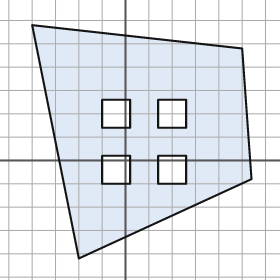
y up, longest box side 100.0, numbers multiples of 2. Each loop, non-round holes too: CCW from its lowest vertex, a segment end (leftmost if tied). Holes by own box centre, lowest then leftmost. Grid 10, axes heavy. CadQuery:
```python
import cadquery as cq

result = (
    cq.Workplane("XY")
    .moveTo(-20.0, -42.0)
    .lineTo(54.0, -8.0)
    .lineTo(50.0, 48.0)
    .lineTo(-40.0, 58.0)
    .close()
    .moveTo(-10.0, -10.0)
    .lineTo(2.0, -10.0)
    .lineTo(2.0, 2.0)
    .lineTo(-10.0, 2.0)
    .close()
    .moveTo(14.0, -10.0)
    .lineTo(26.0, -10.0)
    .lineTo(26.0, 2.0)
    .lineTo(14.0, 2.0)
    .close()
    .moveTo(-10.0, 14.0)
    .lineTo(2.0, 14.0)
    .lineTo(2.0, 26.0)
    .lineTo(-10.0, 26.0)
    .close()
    .moveTo(14.0, 14.0)
    .lineTo(26.0, 14.0)
    .lineTo(26.0, 26.0)
    .lineTo(14.0, 26.0)
    .close()
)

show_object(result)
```